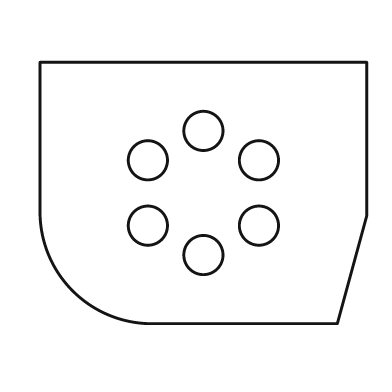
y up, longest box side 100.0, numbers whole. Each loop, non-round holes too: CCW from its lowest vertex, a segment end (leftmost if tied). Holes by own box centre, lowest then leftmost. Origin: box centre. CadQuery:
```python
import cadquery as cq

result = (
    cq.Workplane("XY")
    .moveTo(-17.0, -40.0)
    .lineTo(41.0, -40.0)
    .lineTo(50.0, -7.0)
    .lineTo(50.0, 40.0)
    .lineTo(-50.0, 40.0)
    .lineTo(-50.0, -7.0)
    .threePointArc((-40.0, -30.0), (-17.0, -40.0))
    .close()
    .moveTo(0.0, -19.0)
    .circle(6.0)
    .moveTo(-17.0, -10.0)
    .circle(6.0)
    .moveTo(17.0, -10.0)
    .circle(6.0)
    .moveTo(-17.0, 10.0)
    .circle(6.0)
    .moveTo(17.0, 10.0)
    .circle(6.0)
    .moveTo(0.0, 19.0)
    .circle(6.0)
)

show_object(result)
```